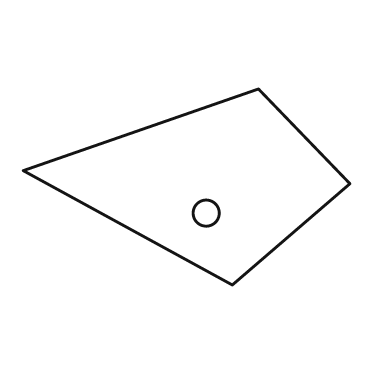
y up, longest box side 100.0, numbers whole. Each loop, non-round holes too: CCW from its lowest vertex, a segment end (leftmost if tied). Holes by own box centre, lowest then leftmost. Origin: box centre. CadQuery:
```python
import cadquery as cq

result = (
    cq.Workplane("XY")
    .moveTo(14.0, -30.0)
    .lineTo(50.0, 1.0)
    .lineTo(22.0, 30.0)
    .lineTo(-50.0, 5.0)
    .close()
    .moveTo(6.0, -8.0)
    .circle(4.0)
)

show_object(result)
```